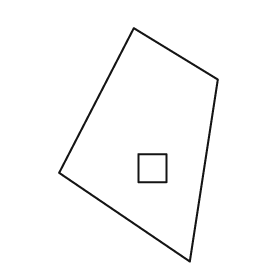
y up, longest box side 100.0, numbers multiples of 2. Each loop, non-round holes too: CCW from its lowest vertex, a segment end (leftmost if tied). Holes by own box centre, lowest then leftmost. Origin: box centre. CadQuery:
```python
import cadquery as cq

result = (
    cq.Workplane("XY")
    .moveTo(22.0, -50.0)
    .lineTo(34.0, 28.0)
    .lineTo(-2.0, 50.0)
    .lineTo(-34.0, -12.0)
    .close()
    .moveTo(0.0, -16.0)
    .lineTo(12.0, -16.0)
    .lineTo(12.0, -4.0)
    .lineTo(0.0, -4.0)
    .close()
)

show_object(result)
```